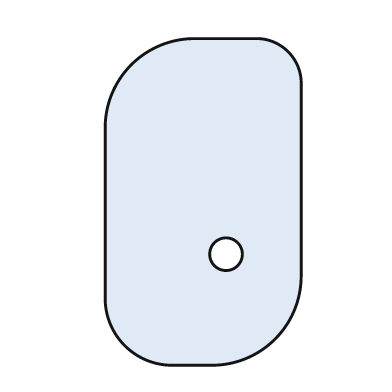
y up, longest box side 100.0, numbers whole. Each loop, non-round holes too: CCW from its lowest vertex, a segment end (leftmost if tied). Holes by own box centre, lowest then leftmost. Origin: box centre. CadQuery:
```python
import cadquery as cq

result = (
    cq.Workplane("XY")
    .moveTo(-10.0, -50.0)
    .lineTo(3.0, -50.0)
    .threePointArc((22.0, -42.0), (30.0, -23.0))
    .lineTo(30.0, 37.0)
    .threePointArc((26.0, 46.0), (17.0, 50.0))
    .lineTo(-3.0, 50.0)
    .threePointArc((-22.0, 42.0), (-30.0, 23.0))
    .lineTo(-30.0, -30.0)
    .threePointArc((-24.0, -44.0), (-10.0, -50.0))
    .close()
    .moveTo(7.0, -16.0)
    .circle(5.0)
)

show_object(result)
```